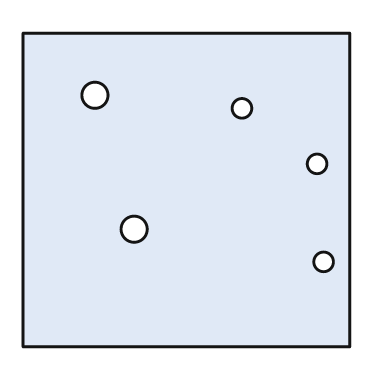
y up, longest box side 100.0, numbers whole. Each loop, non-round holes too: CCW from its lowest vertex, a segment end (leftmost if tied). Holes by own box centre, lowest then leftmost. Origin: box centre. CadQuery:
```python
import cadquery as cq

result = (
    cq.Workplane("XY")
    .moveTo(-50.0, -48.0)
    .lineTo(50.0, -48.0)
    .lineTo(50.0, 48.0)
    .lineTo(-50.0, 48.0)
    .close()
    .moveTo(42.0, -22.0)
    .circle(3.0)
    .moveTo(-16.0, -12.0)
    .circle(4.0)
    .moveTo(40.0, 8.0)
    .circle(3.0)
    .moveTo(17.0, 25.0)
    .circle(3.0)
    .moveTo(-28.0, 29.0)
    .circle(4.0)
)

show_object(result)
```